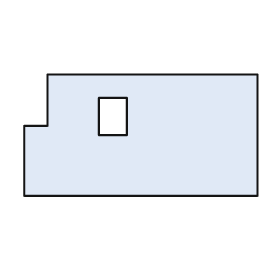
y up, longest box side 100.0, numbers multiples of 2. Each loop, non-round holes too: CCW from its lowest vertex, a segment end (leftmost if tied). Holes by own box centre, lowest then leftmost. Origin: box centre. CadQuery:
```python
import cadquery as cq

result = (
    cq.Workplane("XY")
    .moveTo(-50.0, -26.0)
    .lineTo(50.0, -26.0)
    .lineTo(50.0, 26.0)
    .lineTo(-40.0, 26.0)
    .lineTo(-40.0, 4.0)
    .lineTo(-50.0, 4.0)
    .close()
    .moveTo(-18.0, 0.0)
    .lineTo(-6.0, 0.0)
    .lineTo(-6.0, 16.0)
    .lineTo(-18.0, 16.0)
    .close()
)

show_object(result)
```